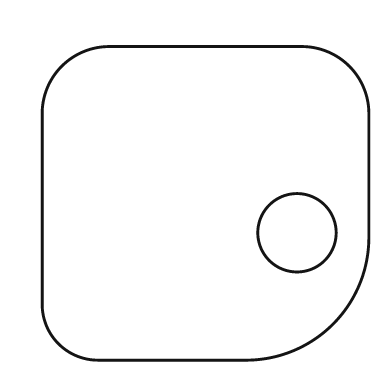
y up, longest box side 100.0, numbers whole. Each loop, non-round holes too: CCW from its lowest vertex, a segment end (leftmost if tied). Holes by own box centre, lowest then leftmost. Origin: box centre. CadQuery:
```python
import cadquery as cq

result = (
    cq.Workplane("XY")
    .moveTo(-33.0, -48.0)
    .lineTo(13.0, -48.0)
    .threePointArc((39.0, -37.0), (50.0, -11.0))
    .lineTo(50.0, 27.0)
    .threePointArc((44.0, 42.0), (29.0, 48.0))
    .lineTo(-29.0, 48.0)
    .threePointArc((-44.0, 42.0), (-50.0, 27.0))
    .lineTo(-50.0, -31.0)
    .threePointArc((-45.0, -43.0), (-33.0, -48.0))
    .close()
    .moveTo(28.0, -9.0)
    .circle(12.0)
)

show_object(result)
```